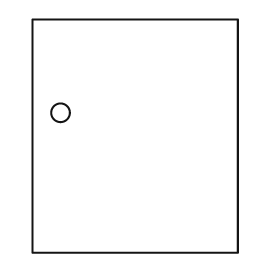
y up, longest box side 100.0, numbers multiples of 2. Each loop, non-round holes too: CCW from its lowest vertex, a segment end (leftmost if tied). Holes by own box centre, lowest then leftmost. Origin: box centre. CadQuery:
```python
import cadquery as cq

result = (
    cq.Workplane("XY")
    .moveTo(-44.0, -50.0)
    .lineTo(44.0, -50.0)
    .lineTo(44.0, 50.0)
    .lineTo(-44.0, 50.0)
    .close()
    .moveTo(-32.0, 10.0)
    .circle(4.0)
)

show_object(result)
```